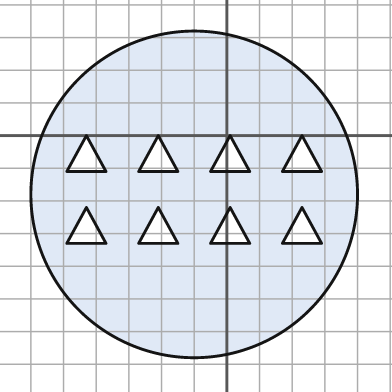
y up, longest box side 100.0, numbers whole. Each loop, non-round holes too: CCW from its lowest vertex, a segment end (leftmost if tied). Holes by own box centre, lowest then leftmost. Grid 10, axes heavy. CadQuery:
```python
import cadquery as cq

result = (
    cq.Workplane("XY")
    .moveTo(-10.0, -18.0)
    .circle(50.0)
    .moveTo(-49.0, -33.0)
    .lineTo(-37.0, -33.0)
    .lineTo(-43.0, -22.0)
    .close()
    .moveTo(-27.0, -33.0)
    .lineTo(-15.0, -33.0)
    .lineTo(-21.0, -22.0)
    .close()
    .moveTo(-5.0, -33.0)
    .lineTo(7.0, -33.0)
    .lineTo(1.0, -22.0)
    .close()
    .moveTo(17.0, -33.0)
    .lineTo(29.0, -33.0)
    .lineTo(23.0, -22.0)
    .close()
    .moveTo(-49.0, -11.0)
    .lineTo(-37.0, -11.0)
    .lineTo(-43.0, 0.0)
    .close()
    .moveTo(-27.0, -11.0)
    .lineTo(-15.0, -11.0)
    .lineTo(-21.0, 0.0)
    .close()
    .moveTo(-5.0, -11.0)
    .lineTo(7.0, -11.0)
    .lineTo(1.0, 0.0)
    .close()
    .moveTo(17.0, -11.0)
    .lineTo(29.0, -11.0)
    .lineTo(23.0, 0.0)
    .close()
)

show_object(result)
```